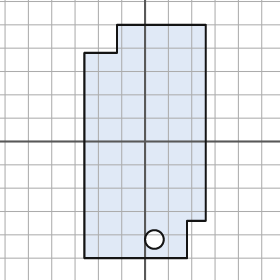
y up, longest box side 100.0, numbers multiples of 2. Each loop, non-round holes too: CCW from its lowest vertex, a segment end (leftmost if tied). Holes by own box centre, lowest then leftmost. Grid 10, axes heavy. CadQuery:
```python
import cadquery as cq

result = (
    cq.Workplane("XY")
    .moveTo(-26.0, -50.0)
    .lineTo(18.0, -50.0)
    .lineTo(18.0, -34.0)
    .lineTo(26.0, -34.0)
    .lineTo(26.0, 50.0)
    .lineTo(-12.0, 50.0)
    .lineTo(-12.0, 38.0)
    .lineTo(-26.0, 38.0)
    .close()
    .moveTo(4.0, -42.0)
    .circle(4.0)
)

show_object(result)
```